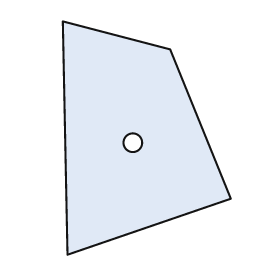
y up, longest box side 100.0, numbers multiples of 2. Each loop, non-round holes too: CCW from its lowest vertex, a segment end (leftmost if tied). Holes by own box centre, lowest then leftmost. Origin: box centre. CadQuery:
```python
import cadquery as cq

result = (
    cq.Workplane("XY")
    .moveTo(-34.0, -50.0)
    .lineTo(36.0, -26.0)
    .lineTo(10.0, 38.0)
    .lineTo(-36.0, 50.0)
    .close()
    .moveTo(-6.0, -2.0)
    .circle(4.0)
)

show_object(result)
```